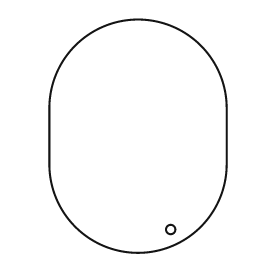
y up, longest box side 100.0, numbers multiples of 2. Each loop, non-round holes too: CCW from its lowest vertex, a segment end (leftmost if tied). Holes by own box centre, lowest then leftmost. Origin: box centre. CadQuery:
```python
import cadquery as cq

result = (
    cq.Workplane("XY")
    .moveTo(-38.0, -12.0)
    .threePointArc((0.0, -50.0), (38.0, -12.0))
    .lineTo(38.0, 12.0)
    .threePointArc((0.0, 50.0), (-38.0, 12.0))
    .close()
    .moveTo(14.0, -40.0)
    .circle(2.0)
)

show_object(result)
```